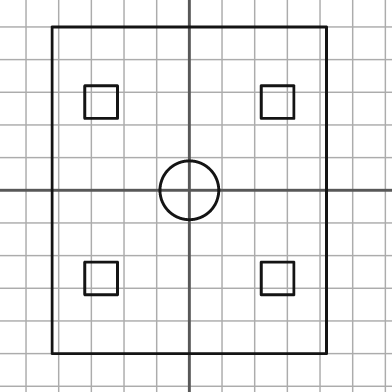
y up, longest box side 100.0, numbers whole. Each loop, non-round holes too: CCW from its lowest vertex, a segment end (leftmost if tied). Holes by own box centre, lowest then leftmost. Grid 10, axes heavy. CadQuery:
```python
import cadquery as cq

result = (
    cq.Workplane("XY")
    .moveTo(-42.0, -50.0)
    .lineTo(42.0, -50.0)
    .lineTo(42.0, 50.0)
    .lineTo(-42.0, 50.0)
    .close()
    .moveTo(-32.0, -32.0)
    .lineTo(-22.0, -32.0)
    .lineTo(-22.0, -22.0)
    .lineTo(-32.0, -22.0)
    .close()
    .moveTo(22.0, -32.0)
    .lineTo(32.0, -32.0)
    .lineTo(32.0, -22.0)
    .lineTo(22.0, -22.0)
    .close()
    .moveTo(0.0, 0.0)
    .circle(9.0)
    .moveTo(-32.0, 22.0)
    .lineTo(-22.0, 22.0)
    .lineTo(-22.0, 32.0)
    .lineTo(-32.0, 32.0)
    .close()
    .moveTo(22.0, 22.0)
    .lineTo(32.0, 22.0)
    .lineTo(32.0, 32.0)
    .lineTo(22.0, 32.0)
    .close()
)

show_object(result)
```